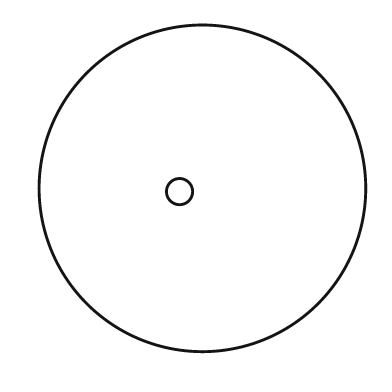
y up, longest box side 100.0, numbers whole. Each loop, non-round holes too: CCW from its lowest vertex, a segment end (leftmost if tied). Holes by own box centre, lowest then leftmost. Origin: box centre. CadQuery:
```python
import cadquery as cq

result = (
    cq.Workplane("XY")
    .moveTo(0.0, 0.0)
    .circle(50.0)
    .moveTo(-7.0, -1.0)
    .circle(4.0)
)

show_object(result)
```